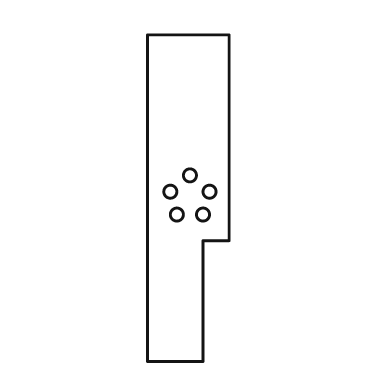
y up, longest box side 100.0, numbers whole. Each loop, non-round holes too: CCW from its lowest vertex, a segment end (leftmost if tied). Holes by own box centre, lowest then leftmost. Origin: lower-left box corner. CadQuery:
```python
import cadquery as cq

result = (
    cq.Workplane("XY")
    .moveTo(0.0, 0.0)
    .lineTo(17.0, 0.0)
    .lineTo(17.0, 37.0)
    .lineTo(25.0, 37.0)
    .lineTo(25.0, 100.0)
    .lineTo(0.0, 100.0)
    .close()
    .moveTo(9.0, 45.0)
    .circle(2.0)
    .moveTo(17.0, 45.0)
    .circle(2.0)
    .moveTo(7.0, 52.0)
    .circle(2.0)
    .moveTo(19.0, 52.0)
    .circle(2.0)
    .moveTo(13.0, 57.0)
    .circle(2.0)
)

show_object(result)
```